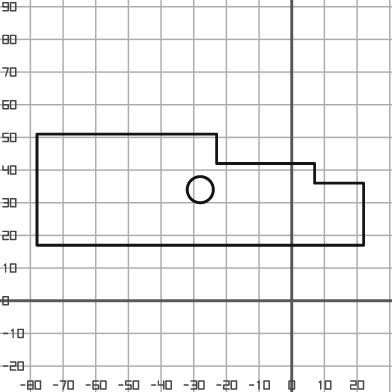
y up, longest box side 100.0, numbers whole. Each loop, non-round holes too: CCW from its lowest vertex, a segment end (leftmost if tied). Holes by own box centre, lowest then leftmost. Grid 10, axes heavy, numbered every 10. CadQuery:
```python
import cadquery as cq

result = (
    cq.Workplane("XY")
    .moveTo(-78.0, 17.0)
    .lineTo(22.0, 17.0)
    .lineTo(22.0, 36.0)
    .lineTo(7.0, 36.0)
    .lineTo(7.0, 42.0)
    .lineTo(-23.0, 42.0)
    .lineTo(-23.0, 51.0)
    .lineTo(-78.0, 51.0)
    .close()
    .moveTo(-28.0, 34.0)
    .circle(4.0)
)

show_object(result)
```